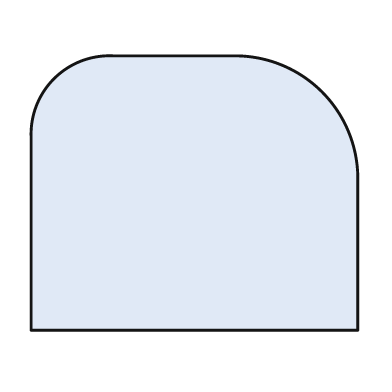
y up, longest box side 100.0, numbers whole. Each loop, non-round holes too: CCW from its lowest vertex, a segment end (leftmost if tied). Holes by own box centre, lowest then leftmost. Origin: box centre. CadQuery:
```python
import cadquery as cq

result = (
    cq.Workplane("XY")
    .moveTo(-50.0, -42.0)
    .lineTo(50.0, -42.0)
    .lineTo(50.0, 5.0)
    .threePointArc((39.0, 31.0), (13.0, 42.0))
    .lineTo(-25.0, 42.0)
    .threePointArc((-43.0, 35.0), (-50.0, 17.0))
    .close()
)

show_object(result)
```